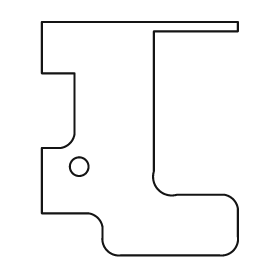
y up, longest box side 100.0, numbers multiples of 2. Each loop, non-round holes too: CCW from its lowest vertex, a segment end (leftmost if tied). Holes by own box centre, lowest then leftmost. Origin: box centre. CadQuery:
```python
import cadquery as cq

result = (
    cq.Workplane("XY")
    .moveTo(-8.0, -50.0)
    .lineTo(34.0, -50.0)
    .threePointArc((40.0, -48.0), (42.0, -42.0))
    .lineTo(42.0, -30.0)
    .threePointArc((40.0, -26.0), (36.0, -24.0))
    .lineTo(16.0, -24.0)
    .threePointArc((8.0, -22.0), (6.0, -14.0))
    .lineTo(6.0, 46.0)
    .lineTo(42.0, 46.0)
    .lineTo(42.0, 50.0)
    .lineTo(-42.0, 50.0)
    .lineTo(-42.0, 28.0)
    .lineTo(-28.0, 28.0)
    .lineTo(-28.0, 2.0)
    .threePointArc((-30.0, -2.0), (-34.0, -4.0))
    .lineTo(-42.0, -4.0)
    .lineTo(-42.0, -32.0)
    .lineTo(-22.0, -32.0)
    .threePointArc((-18.0, -34.0), (-16.0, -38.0))
    .lineTo(-16.0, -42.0)
    .threePointArc((-14.0, -48.0), (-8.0, -50.0))
    .close()
    .moveTo(-26.0, -12.0)
    .circle(4.0)
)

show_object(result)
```